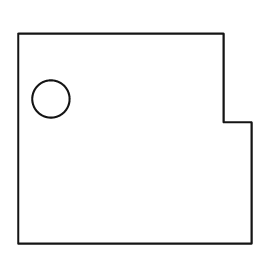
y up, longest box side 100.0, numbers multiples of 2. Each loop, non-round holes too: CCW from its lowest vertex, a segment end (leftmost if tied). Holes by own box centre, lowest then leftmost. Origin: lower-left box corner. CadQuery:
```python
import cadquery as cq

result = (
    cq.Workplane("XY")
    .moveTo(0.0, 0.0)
    .lineTo(100.0, 0.0)
    .lineTo(100.0, 52.0)
    .lineTo(88.0, 52.0)
    .lineTo(88.0, 90.0)
    .lineTo(0.0, 90.0)
    .close()
    .moveTo(14.0, 62.0)
    .circle(8.0)
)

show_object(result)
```